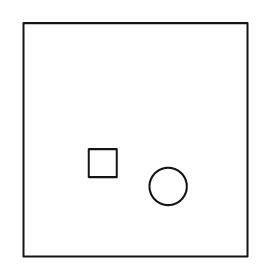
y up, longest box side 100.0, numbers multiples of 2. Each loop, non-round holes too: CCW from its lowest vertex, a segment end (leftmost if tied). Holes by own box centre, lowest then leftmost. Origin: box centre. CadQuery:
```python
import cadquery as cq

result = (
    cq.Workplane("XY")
    .moveTo(-48.0, -50.0)
    .lineTo(48.0, -50.0)
    .lineTo(48.0, 50.0)
    .lineTo(-48.0, 50.0)
    .close()
    .moveTo(14.0, -20.0)
    .circle(8.0)
    .moveTo(-20.0, -16.0)
    .lineTo(-8.0, -16.0)
    .lineTo(-8.0, -4.0)
    .lineTo(-20.0, -4.0)
    .close()
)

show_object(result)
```